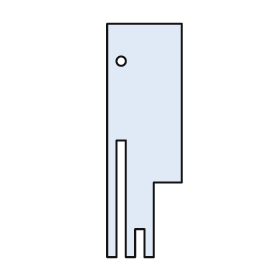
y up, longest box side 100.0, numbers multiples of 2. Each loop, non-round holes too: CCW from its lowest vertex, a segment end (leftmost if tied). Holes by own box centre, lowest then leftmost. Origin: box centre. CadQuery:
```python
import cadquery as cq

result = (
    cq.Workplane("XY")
    .moveTo(-16.0, -50.0)
    .lineTo(-12.0, -50.0)
    .lineTo(-12.0, 0.0)
    .lineTo(-8.0, 0.0)
    .lineTo(-8.0, -50.0)
    .lineTo(-4.0, -50.0)
    .lineTo(-4.0, -38.0)
    .lineTo(0.0, -38.0)
    .lineTo(0.0, -50.0)
    .lineTo(4.0, -50.0)
    .lineTo(4.0, -18.0)
    .lineTo(16.0, -18.0)
    .lineTo(16.0, 50.0)
    .lineTo(-16.0, 50.0)
    .close()
    .moveTo(-10.0, 34.0)
    .circle(2.0)
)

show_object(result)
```